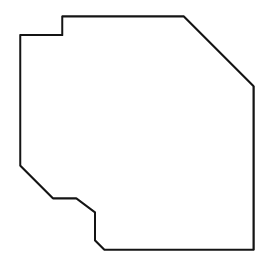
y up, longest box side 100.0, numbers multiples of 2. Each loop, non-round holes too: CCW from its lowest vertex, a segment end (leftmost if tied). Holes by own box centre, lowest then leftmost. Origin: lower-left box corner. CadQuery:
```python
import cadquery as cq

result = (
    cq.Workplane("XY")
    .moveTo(36.0, 0.0)
    .lineTo(100.0, 0.0)
    .lineTo(100.0, 70.0)
    .lineTo(70.0, 100.0)
    .lineTo(18.0, 100.0)
    .lineTo(18.0, 92.0)
    .lineTo(0.0, 92.0)
    .lineTo(0.0, 36.0)
    .lineTo(14.0, 22.0)
    .lineTo(24.0, 22.0)
    .lineTo(32.0, 16.0)
    .lineTo(32.0, 4.0)
    .close()
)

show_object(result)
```